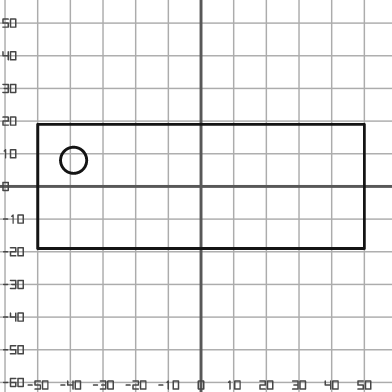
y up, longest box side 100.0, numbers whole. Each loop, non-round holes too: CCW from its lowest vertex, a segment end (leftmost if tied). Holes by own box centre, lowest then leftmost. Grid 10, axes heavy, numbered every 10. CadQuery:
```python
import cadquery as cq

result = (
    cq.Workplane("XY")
    .moveTo(-50.0, -19.0)
    .lineTo(50.0, -19.0)
    .lineTo(50.0, 19.0)
    .lineTo(-50.0, 19.0)
    .close()
    .moveTo(-39.0, 8.0)
    .circle(4.0)
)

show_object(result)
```